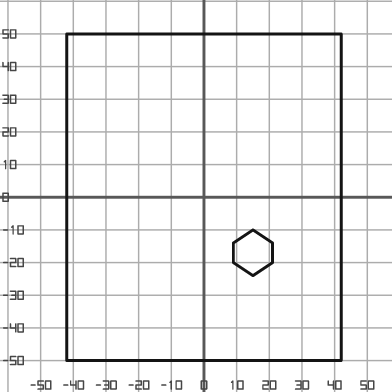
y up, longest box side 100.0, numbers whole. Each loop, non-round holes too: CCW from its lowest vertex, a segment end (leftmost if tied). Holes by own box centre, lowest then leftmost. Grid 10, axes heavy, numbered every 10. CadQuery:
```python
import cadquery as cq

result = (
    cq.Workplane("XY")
    .moveTo(-42.0, -50.0)
    .lineTo(42.0, -50.0)
    .lineTo(42.0, 50.0)
    .lineTo(-42.0, 50.0)
    .close()
    .moveTo(15.0, -24.0)
    .lineTo(21.0, -20.0)
    .lineTo(21.0, -14.0)
    .lineTo(15.0, -10.0)
    .lineTo(9.0, -14.0)
    .lineTo(9.0, -20.0)
    .close()
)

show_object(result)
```